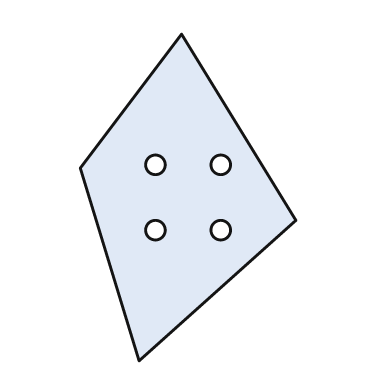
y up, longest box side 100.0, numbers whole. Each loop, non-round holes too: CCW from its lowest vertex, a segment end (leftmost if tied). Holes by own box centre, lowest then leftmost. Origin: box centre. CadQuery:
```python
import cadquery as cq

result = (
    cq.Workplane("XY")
    .moveTo(-15.0, -50.0)
    .lineTo(33.0, -7.0)
    .lineTo(-2.0, 50.0)
    .lineTo(-33.0, 9.0)
    .close()
    .moveTo(-10.0, -10.0)
    .circle(3.0)
    .moveTo(10.0, -10.0)
    .circle(3.0)
    .moveTo(-10.0, 10.0)
    .circle(3.0)
    .moveTo(10.0, 10.0)
    .circle(3.0)
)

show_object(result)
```